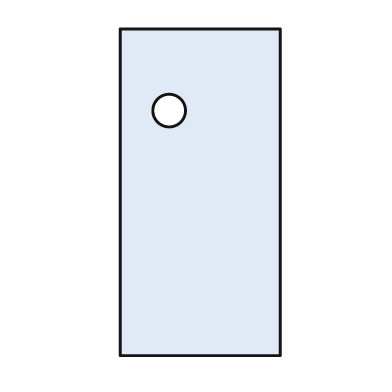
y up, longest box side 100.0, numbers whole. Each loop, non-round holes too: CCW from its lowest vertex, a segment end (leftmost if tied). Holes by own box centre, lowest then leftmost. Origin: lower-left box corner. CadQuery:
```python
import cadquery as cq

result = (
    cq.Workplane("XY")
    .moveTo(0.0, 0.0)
    .lineTo(49.0, 0.0)
    .lineTo(49.0, 100.0)
    .lineTo(0.0, 100.0)
    .close()
    .moveTo(15.0, 75.0)
    .circle(5.0)
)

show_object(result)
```